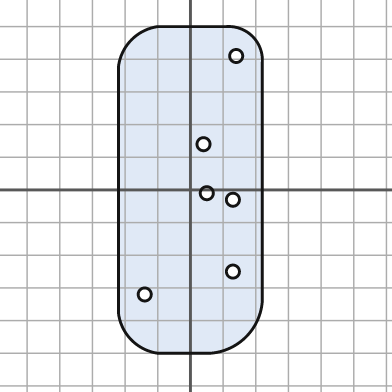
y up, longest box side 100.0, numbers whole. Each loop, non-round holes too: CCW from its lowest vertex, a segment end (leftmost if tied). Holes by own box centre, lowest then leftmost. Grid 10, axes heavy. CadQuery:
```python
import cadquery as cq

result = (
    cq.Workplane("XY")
    .moveTo(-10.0, -50.0)
    .lineTo(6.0, -50.0)
    .threePointArc((17.0, -45.0), (22.0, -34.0))
    .lineTo(22.0, 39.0)
    .threePointArc((19.0, 47.0), (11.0, 50.0))
    .lineTo(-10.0, 50.0)
    .threePointArc((-18.0, 46.0), (-22.0, 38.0))
    .lineTo(-22.0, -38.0)
    .threePointArc((-18.0, -46.0), (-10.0, -50.0))
    .close()
    .moveTo(-14.0, -32.0)
    .circle(2.0)
    .moveTo(13.0, -25.0)
    .circle(2.0)
    .moveTo(13.0, -3.0)
    .circle(2.0)
    .moveTo(5.0, -1.0)
    .circle(2.0)
    .moveTo(4.0, 14.0)
    .circle(2.0)
    .moveTo(14.0, 41.0)
    .circle(2.0)
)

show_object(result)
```